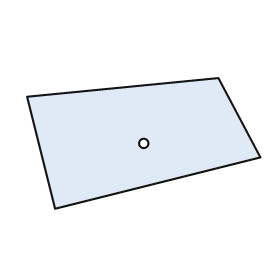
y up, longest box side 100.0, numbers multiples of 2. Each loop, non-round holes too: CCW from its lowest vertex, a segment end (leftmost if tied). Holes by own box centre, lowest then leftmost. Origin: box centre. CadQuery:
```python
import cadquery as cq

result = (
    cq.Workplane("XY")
    .moveTo(-38.0, -28.0)
    .lineTo(50.0, -6.0)
    .lineTo(32.0, 28.0)
    .lineTo(-50.0, 20.0)
    .close()
    .moveTo(0.0, 0.0)
    .circle(2.0)
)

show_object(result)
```